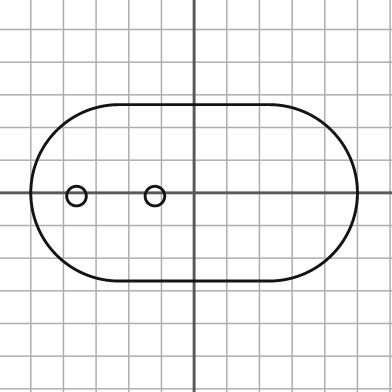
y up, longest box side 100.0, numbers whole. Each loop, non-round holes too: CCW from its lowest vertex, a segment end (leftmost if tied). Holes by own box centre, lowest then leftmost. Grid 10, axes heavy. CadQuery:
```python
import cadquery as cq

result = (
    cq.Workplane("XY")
    .moveTo(-23.0, -27.0)
    .lineTo(23.0, -27.0)
    .threePointArc((50.0, 0.0), (23.0, 27.0))
    .lineTo(-23.0, 27.0)
    .threePointArc((-50.0, 0.0), (-23.0, -27.0))
    .close()
    .moveTo(-36.0, -1.0)
    .circle(3.0)
    .moveTo(-12.0, -1.0)
    .circle(3.0)
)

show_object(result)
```